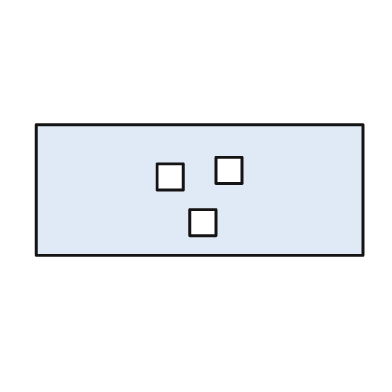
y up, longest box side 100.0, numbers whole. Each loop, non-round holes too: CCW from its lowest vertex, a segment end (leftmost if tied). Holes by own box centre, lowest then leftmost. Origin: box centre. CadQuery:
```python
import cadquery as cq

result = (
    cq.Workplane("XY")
    .moveTo(-50.0, -20.0)
    .lineTo(50.0, -20.0)
    .lineTo(50.0, 20.0)
    .lineTo(-50.0, 20.0)
    .close()
    .moveTo(-3.0, -14.0)
    .lineTo(5.0, -14.0)
    .lineTo(5.0, -6.0)
    .lineTo(-3.0, -6.0)
    .close()
    .moveTo(-13.0, 0.0)
    .lineTo(-5.0, 0.0)
    .lineTo(-5.0, 8.0)
    .lineTo(-13.0, 8.0)
    .close()
    .moveTo(5.0, 2.0)
    .lineTo(13.0, 2.0)
    .lineTo(13.0, 10.0)
    .lineTo(5.0, 10.0)
    .close()
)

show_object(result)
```